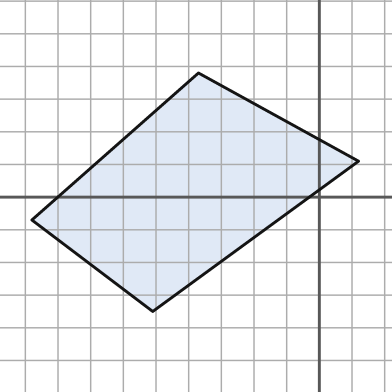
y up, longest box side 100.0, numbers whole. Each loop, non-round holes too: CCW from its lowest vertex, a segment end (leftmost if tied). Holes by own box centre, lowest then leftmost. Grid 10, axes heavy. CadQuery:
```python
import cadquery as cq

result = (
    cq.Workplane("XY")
    .moveTo(-51.0, -35.0)
    .lineTo(12.0, 11.0)
    .lineTo(-37.0, 38.0)
    .lineTo(-88.0, -7.0)
    .close()
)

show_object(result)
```